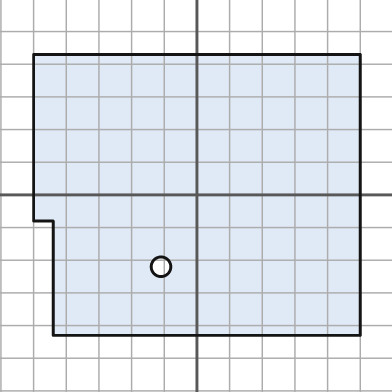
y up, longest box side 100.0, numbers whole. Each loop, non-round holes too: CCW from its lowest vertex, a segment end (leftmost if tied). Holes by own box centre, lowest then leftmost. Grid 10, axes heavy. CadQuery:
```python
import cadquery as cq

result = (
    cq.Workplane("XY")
    .moveTo(-44.0, -43.0)
    .lineTo(50.0, -43.0)
    .lineTo(50.0, 43.0)
    .lineTo(-50.0, 43.0)
    .lineTo(-50.0, -8.0)
    .lineTo(-44.0, -8.0)
    .close()
    .moveTo(-11.0, -22.0)
    .circle(3.0)
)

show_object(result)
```